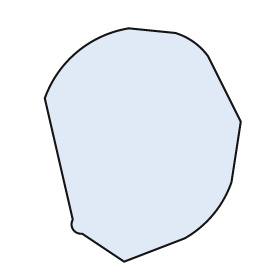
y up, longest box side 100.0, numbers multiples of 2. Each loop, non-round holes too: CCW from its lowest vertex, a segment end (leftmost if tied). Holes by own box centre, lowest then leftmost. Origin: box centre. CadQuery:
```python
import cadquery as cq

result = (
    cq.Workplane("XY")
    .moveTo(-8.0, -50.0)
    .lineTo(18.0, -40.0)
    .threePointArc((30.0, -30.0), (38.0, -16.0))
    .lineTo(42.0, 10.0)
    .lineTo(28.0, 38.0)
    .threePointArc((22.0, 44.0), (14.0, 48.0))
    .lineTo(-6.0, 50.0)
    .threePointArc((-28.0, 40.0), (-42.0, 20.0))
    .lineTo(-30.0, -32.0)
    .threePointArc((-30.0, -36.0), (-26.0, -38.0))
    .close()
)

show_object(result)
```